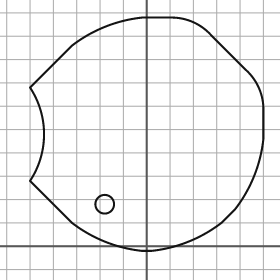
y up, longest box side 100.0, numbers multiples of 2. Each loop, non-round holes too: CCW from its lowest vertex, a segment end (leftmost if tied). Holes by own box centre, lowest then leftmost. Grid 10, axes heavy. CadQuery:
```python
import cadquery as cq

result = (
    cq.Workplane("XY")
    .moveTo(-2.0, -2.0)
    .lineTo(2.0, -2.0)
    .threePointArc((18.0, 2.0), (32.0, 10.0))
    .lineTo(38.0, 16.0)
    .threePointArc((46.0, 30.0), (50.0, 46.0))
    .lineTo(50.0, 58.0)
    .threePointArc((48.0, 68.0), (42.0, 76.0))
    .lineTo(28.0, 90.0)
    .threePointArc((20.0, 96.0), (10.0, 98.0))
    .lineTo(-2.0, 98.0)
    .threePointArc((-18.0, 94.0), (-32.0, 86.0))
    .lineTo(-50.0, 68.0)
    .threePointArc((-44.0, 48.0), (-50.0, 28.0))
    .lineTo(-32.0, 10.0)
    .threePointArc((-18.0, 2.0), (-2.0, -2.0))
    .close()
    .moveTo(-18.0, 18.0)
    .circle(4.0)
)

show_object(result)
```